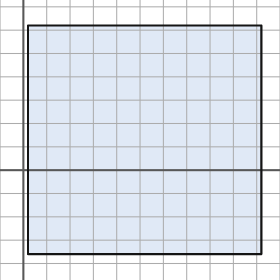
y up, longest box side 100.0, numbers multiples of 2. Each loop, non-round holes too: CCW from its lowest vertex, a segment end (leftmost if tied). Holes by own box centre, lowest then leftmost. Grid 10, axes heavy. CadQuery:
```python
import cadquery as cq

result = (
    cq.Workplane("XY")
    .moveTo(2.0, -36.0)
    .lineTo(102.0, -36.0)
    .lineTo(102.0, 62.0)
    .lineTo(2.0, 62.0)
    .close()
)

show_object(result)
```